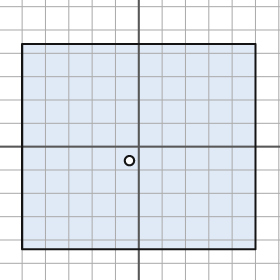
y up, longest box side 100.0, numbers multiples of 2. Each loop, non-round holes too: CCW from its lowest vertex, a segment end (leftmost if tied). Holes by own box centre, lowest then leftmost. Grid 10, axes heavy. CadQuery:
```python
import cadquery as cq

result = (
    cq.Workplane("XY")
    .moveTo(-50.0, -44.0)
    .lineTo(50.0, -44.0)
    .lineTo(50.0, 44.0)
    .lineTo(-50.0, 44.0)
    .close()
    .moveTo(-4.0, -6.0)
    .circle(2.0)
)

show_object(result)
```